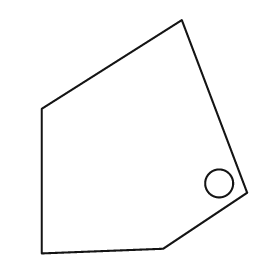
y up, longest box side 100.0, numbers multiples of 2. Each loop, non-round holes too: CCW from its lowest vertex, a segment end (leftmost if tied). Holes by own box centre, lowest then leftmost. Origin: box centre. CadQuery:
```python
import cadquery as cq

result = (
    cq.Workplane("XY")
    .moveTo(-44.0, -50.0)
    .lineTo(8.0, -48.0)
    .lineTo(44.0, -24.0)
    .lineTo(16.0, 50.0)
    .lineTo(-44.0, 12.0)
    .close()
    .moveTo(32.0, -20.0)
    .circle(6.0)
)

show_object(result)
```